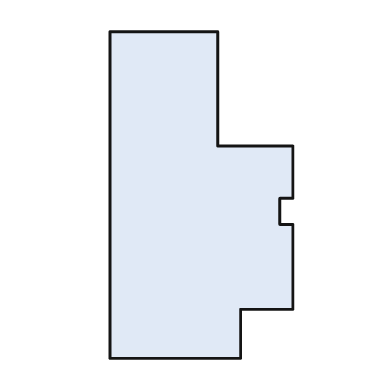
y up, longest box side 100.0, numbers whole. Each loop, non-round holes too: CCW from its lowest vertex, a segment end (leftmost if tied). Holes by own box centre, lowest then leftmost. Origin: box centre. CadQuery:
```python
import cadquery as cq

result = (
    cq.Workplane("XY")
    .moveTo(-28.0, -50.0)
    .lineTo(12.0, -50.0)
    .lineTo(12.0, -35.0)
    .lineTo(28.0, -35.0)
    .lineTo(28.0, -9.0)
    .lineTo(24.0, -9.0)
    .lineTo(24.0, -1.0)
    .lineTo(28.0, -1.0)
    .lineTo(28.0, 15.0)
    .lineTo(5.0, 15.0)
    .lineTo(5.0, 50.0)
    .lineTo(-28.0, 50.0)
    .close()
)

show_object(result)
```